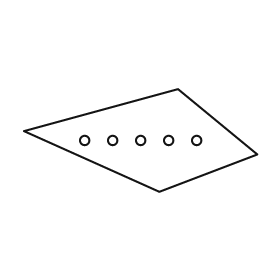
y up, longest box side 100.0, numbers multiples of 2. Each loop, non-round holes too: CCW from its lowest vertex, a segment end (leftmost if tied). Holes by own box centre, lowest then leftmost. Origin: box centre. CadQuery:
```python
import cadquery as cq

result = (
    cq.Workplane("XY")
    .moveTo(8.0, -22.0)
    .lineTo(50.0, -6.0)
    .lineTo(16.0, 22.0)
    .lineTo(-50.0, 4.0)
    .close()
    .moveTo(-24.0, 0.0)
    .circle(2.0)
    .moveTo(-12.0, 0.0)
    .circle(2.0)
    .moveTo(0.0, 0.0)
    .circle(2.0)
    .moveTo(12.0, 0.0)
    .circle(2.0)
    .moveTo(24.0, 0.0)
    .circle(2.0)
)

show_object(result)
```